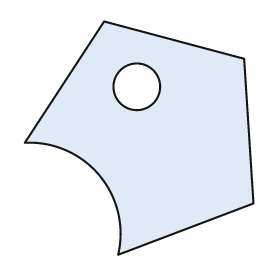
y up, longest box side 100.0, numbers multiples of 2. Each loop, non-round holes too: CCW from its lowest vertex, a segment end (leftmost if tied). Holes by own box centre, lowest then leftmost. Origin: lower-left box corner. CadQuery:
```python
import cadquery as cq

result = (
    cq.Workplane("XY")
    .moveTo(40.0, 0.0)
    .lineTo(98.0, 22.0)
    .lineTo(94.0, 84.0)
    .lineTo(34.0, 100.0)
    .lineTo(0.0, 48.0)
    .threePointArc((32.0, 34.0), (40.0, 0.0))
    .close()
    .moveTo(48.0, 72.0)
    .circle(10.0)
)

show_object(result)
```